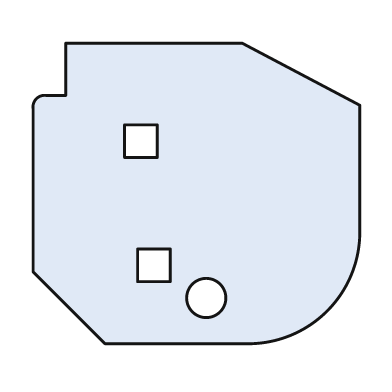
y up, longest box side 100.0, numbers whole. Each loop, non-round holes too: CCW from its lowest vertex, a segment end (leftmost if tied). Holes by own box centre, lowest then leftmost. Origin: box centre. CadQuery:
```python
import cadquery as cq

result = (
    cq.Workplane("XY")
    .moveTo(-28.0, -46.0)
    .lineTo(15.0, -46.0)
    .threePointArc((40.0, -36.0), (50.0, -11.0))
    .lineTo(50.0, 27.0)
    .lineTo(14.0, 46.0)
    .lineTo(-40.0, 46.0)
    .lineTo(-40.0, 30.0)
    .lineTo(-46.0, 30.0)
    .threePointArc((-49.0, 29.0), (-50.0, 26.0))
    .lineTo(-50.0, -24.0)
    .close()
    .moveTo(3.0, -32.0)
    .circle(6.0)
    .moveTo(-18.0, -27.0)
    .lineTo(-8.0, -27.0)
    .lineTo(-8.0, -17.0)
    .lineTo(-18.0, -17.0)
    .close()
    .moveTo(-22.0, 11.0)
    .lineTo(-12.0, 11.0)
    .lineTo(-12.0, 21.0)
    .lineTo(-22.0, 21.0)
    .close()
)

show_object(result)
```